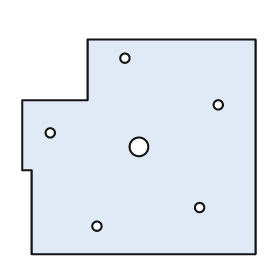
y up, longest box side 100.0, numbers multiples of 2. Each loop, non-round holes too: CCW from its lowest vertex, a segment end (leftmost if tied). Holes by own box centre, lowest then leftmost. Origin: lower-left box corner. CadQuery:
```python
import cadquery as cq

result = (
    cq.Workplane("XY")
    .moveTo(4.0, 0.0)
    .lineTo(100.0, 0.0)
    .lineTo(100.0, 92.0)
    .lineTo(28.0, 92.0)
    .lineTo(28.0, 66.0)
    .lineTo(0.0, 66.0)
    .lineTo(0.0, 36.0)
    .lineTo(4.0, 36.0)
    .close()
    .moveTo(32.0, 12.0)
    .circle(2.0)
    .moveTo(76.0, 20.0)
    .circle(2.0)
    .moveTo(50.0, 46.0)
    .circle(4.0)
    .moveTo(12.0, 52.0)
    .circle(2.0)
    .moveTo(84.0, 64.0)
    .circle(2.0)
    .moveTo(44.0, 84.0)
    .circle(2.0)
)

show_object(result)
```